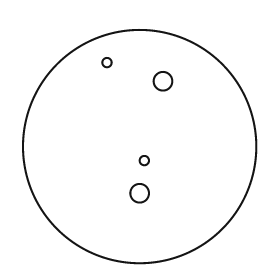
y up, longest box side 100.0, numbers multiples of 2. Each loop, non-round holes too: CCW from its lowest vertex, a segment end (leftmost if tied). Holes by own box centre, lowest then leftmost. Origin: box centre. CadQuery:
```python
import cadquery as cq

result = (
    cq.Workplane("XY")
    .moveTo(0.0, 0.0)
    .circle(50.0)
    .moveTo(0.0, -20.0)
    .circle(4.0)
    .moveTo(2.0, -6.0)
    .circle(2.0)
    .moveTo(10.0, 28.0)
    .circle(4.0)
    .moveTo(-14.0, 36.0)
    .circle(2.0)
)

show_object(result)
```